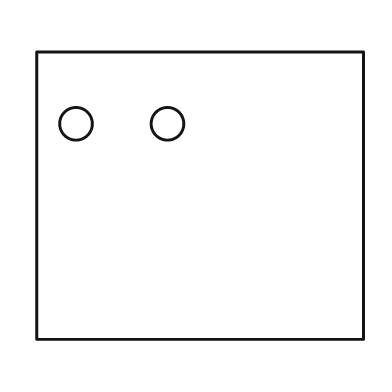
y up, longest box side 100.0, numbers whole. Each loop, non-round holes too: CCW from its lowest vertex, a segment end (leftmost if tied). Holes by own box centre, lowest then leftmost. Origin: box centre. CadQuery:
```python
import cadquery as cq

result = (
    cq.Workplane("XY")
    .moveTo(-50.0, -44.0)
    .lineTo(50.0, -44.0)
    .lineTo(50.0, 44.0)
    .lineTo(-50.0, 44.0)
    .close()
    .moveTo(-38.0, 22.0)
    .circle(5.0)
    .moveTo(-10.0, 22.0)
    .circle(5.0)
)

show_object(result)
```